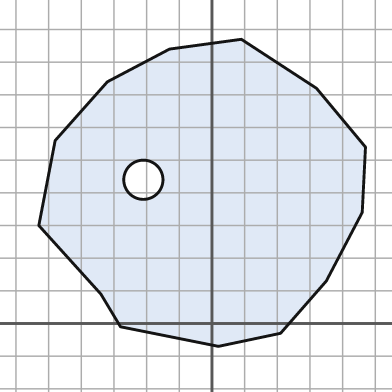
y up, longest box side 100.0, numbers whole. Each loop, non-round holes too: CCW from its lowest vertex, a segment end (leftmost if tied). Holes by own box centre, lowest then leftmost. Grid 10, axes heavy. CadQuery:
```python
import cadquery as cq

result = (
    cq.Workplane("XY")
    .moveTo(2.0, -7.0)
    .lineTo(21.0, -3.0)
    .lineTo(35.0, 13.0)
    .lineTo(46.0, 34.0)
    .lineTo(47.0, 54.0)
    .lineTo(32.0, 72.0)
    .lineTo(9.0, 87.0)
    .lineTo(-13.0, 84.0)
    .lineTo(-32.0, 74.0)
    .lineTo(-48.0, 56.0)
    .lineTo(-53.0, 30.0)
    .lineTo(-34.0, 9.0)
    .lineTo(-28.0, -1.0)
    .close()
    .moveTo(-21.0, 44.0)
    .circle(6.0)
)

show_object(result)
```